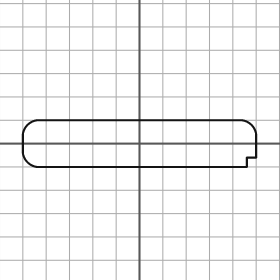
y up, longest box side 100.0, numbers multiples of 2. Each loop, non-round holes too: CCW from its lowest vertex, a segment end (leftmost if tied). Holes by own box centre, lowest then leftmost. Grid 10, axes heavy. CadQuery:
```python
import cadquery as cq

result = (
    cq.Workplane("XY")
    .moveTo(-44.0, -10.0)
    .lineTo(46.0, -10.0)
    .lineTo(46.0, -6.0)
    .lineTo(50.0, -6.0)
    .lineTo(50.0, 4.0)
    .threePointArc((48.0, 8.0), (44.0, 10.0))
    .lineTo(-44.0, 10.0)
    .threePointArc((-48.0, 8.0), (-50.0, 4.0))
    .lineTo(-50.0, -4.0)
    .threePointArc((-48.0, -8.0), (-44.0, -10.0))
    .close()
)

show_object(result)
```